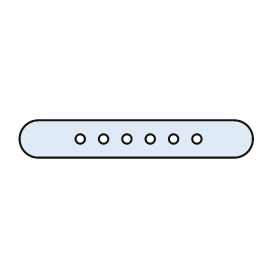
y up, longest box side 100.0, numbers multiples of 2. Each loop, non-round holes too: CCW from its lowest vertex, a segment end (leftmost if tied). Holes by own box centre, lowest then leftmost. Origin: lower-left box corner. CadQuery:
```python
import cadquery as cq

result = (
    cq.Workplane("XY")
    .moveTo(8.0, 0.0)
    .lineTo(92.0, 0.0)
    .threePointArc((100.0, 8.0), (92.0, 16.0))
    .lineTo(8.0, 16.0)
    .threePointArc((0.0, 8.0), (8.0, 0.0))
    .close()
    .moveTo(26.0, 8.0)
    .circle(2.0)
    .moveTo(36.0, 8.0)
    .circle(2.0)
    .moveTo(46.0, 8.0)
    .circle(2.0)
    .moveTo(56.0, 8.0)
    .circle(2.0)
    .moveTo(66.0, 8.0)
    .circle(2.0)
    .moveTo(76.0, 8.0)
    .circle(2.0)
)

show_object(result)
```